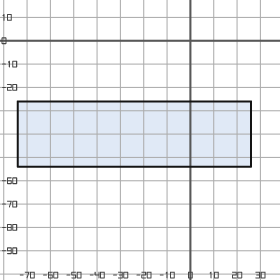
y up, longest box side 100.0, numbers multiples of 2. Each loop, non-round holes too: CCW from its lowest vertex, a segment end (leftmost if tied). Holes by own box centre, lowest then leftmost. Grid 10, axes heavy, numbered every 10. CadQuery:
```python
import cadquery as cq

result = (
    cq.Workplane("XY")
    .moveTo(-74.0, -54.0)
    .lineTo(26.0, -54.0)
    .lineTo(26.0, -26.0)
    .lineTo(-74.0, -26.0)
    .close()
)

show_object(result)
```